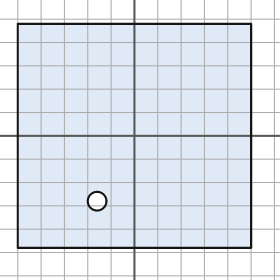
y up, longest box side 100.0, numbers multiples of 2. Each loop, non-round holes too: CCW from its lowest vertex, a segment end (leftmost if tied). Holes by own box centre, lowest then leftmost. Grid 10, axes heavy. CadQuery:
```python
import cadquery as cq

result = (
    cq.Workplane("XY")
    .moveTo(-50.0, -48.0)
    .lineTo(50.0, -48.0)
    .lineTo(50.0, 48.0)
    .lineTo(-50.0, 48.0)
    .close()
    .moveTo(-16.0, -28.0)
    .circle(4.0)
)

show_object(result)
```